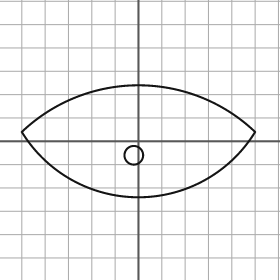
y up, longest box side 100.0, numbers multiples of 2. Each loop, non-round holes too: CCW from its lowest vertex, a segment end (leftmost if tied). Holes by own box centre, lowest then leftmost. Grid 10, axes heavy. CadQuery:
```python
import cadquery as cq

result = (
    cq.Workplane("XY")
    .moveTo(-50.0, 4.0)
    .threePointArc((0.0, -24.0), (50.0, 4.0))
    .threePointArc((0.0, 24.0), (-50.0, 4.0))
    .close()
    .moveTo(-2.0, -6.0)
    .circle(4.0)
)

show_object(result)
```